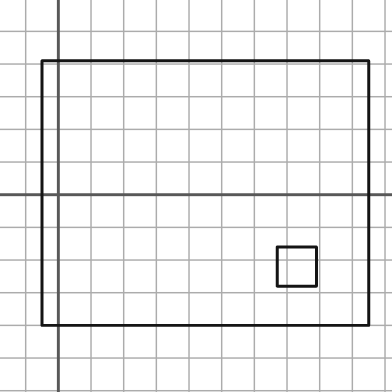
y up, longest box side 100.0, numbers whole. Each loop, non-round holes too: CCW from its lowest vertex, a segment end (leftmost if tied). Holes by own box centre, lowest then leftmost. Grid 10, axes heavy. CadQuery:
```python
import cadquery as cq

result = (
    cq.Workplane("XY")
    .moveTo(-5.0, -40.0)
    .lineTo(95.0, -40.0)
    .lineTo(95.0, 41.0)
    .lineTo(-5.0, 41.0)
    .close()
    .moveTo(67.0, -28.0)
    .lineTo(79.0, -28.0)
    .lineTo(79.0, -16.0)
    .lineTo(67.0, -16.0)
    .close()
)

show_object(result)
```